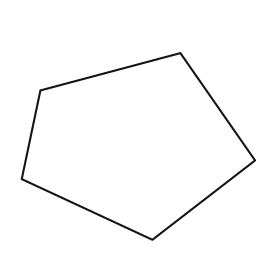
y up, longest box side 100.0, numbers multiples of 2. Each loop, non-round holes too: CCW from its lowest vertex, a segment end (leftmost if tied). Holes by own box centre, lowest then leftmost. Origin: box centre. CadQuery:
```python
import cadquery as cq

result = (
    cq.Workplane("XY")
    .moveTo(6.0, -40.0)
    .lineTo(50.0, -6.0)
    .lineTo(18.0, 40.0)
    .lineTo(-42.0, 24.0)
    .lineTo(-50.0, -14.0)
    .close()
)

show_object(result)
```